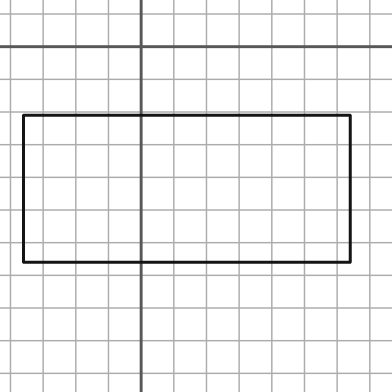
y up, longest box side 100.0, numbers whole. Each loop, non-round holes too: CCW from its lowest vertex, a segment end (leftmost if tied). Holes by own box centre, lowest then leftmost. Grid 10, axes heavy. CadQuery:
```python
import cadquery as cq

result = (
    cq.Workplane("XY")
    .moveTo(-36.0, -66.0)
    .lineTo(64.0, -66.0)
    .lineTo(64.0, -21.0)
    .lineTo(-36.0, -21.0)
    .close()
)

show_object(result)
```